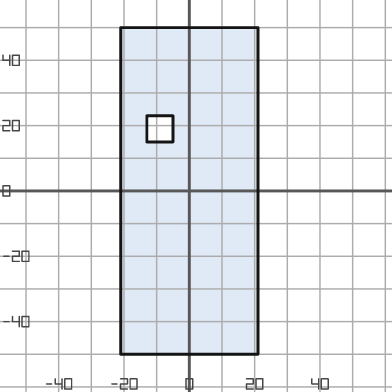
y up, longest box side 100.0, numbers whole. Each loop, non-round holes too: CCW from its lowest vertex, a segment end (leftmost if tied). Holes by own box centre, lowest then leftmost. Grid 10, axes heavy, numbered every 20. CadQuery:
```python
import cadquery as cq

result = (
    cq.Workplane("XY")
    .moveTo(-21.0, -50.0)
    .lineTo(21.0, -50.0)
    .lineTo(21.0, 50.0)
    .lineTo(-21.0, 50.0)
    .close()
    .moveTo(-13.0, 15.0)
    .lineTo(-5.0, 15.0)
    .lineTo(-5.0, 23.0)
    .lineTo(-13.0, 23.0)
    .close()
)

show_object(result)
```